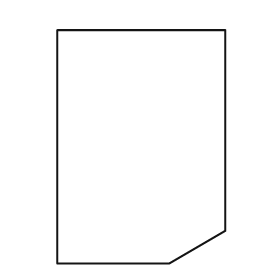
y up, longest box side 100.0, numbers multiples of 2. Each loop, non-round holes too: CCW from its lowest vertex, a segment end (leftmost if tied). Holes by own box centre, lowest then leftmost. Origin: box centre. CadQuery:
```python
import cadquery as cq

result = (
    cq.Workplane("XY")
    .moveTo(-36.0, -50.0)
    .lineTo(12.0, -50.0)
    .lineTo(36.0, -36.0)
    .lineTo(36.0, 50.0)
    .lineTo(-36.0, 50.0)
    .close()
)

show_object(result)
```